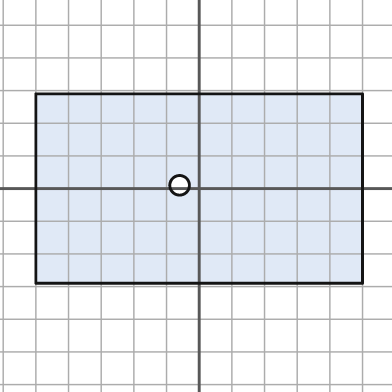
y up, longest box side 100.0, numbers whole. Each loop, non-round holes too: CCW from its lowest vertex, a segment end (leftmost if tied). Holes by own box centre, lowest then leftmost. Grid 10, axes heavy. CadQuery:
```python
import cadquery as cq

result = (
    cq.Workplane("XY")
    .moveTo(-50.0, -29.0)
    .lineTo(50.0, -29.0)
    .lineTo(50.0, 29.0)
    .lineTo(-50.0, 29.0)
    .close()
    .moveTo(-6.0, 1.0)
    .circle(3.0)
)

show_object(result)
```